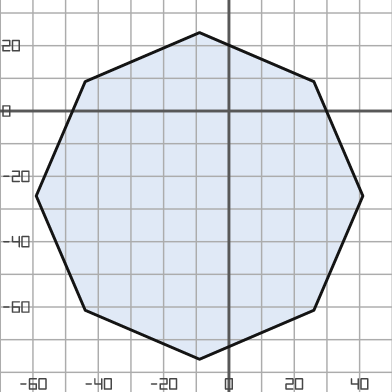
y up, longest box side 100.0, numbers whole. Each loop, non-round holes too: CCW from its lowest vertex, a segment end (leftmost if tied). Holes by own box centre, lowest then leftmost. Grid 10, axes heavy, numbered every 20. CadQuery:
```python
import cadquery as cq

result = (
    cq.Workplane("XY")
    .moveTo(-9.0, -76.0)
    .lineTo(26.0, -61.0)
    .lineTo(41.0, -26.0)
    .lineTo(26.0, 9.0)
    .lineTo(-9.0, 24.0)
    .lineTo(-44.0, 9.0)
    .lineTo(-59.0, -26.0)
    .lineTo(-44.0, -61.0)
    .close()
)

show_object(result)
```